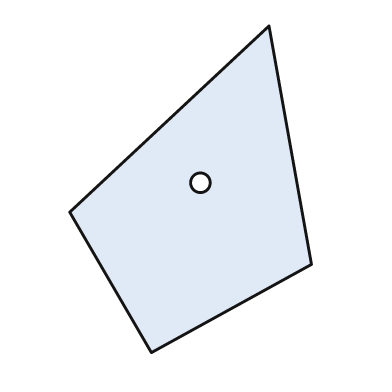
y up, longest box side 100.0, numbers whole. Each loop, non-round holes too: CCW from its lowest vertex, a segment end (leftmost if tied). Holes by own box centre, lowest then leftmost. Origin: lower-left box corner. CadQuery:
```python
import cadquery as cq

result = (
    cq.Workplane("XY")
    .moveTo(25.0, 0.0)
    .lineTo(74.0, 27.0)
    .lineTo(61.0, 100.0)
    .lineTo(0.0, 43.0)
    .close()
    .moveTo(40.0, 52.0)
    .circle(3.0)
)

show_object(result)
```